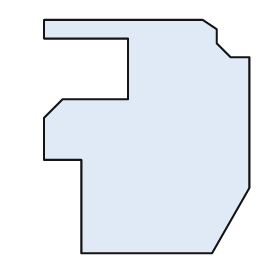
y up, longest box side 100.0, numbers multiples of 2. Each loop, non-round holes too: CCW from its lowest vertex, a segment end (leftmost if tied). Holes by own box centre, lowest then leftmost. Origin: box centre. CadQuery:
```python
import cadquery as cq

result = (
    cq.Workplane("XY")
    .moveTo(-28.0, -50.0)
    .lineTo(28.0, -50.0)
    .lineTo(44.0, -22.0)
    .lineTo(44.0, 34.0)
    .lineTo(36.0, 34.0)
    .lineTo(30.0, 40.0)
    .lineTo(30.0, 46.0)
    .lineTo(24.0, 50.0)
    .lineTo(-44.0, 50.0)
    .lineTo(-44.0, 42.0)
    .lineTo(-8.0, 42.0)
    .lineTo(-8.0, 16.0)
    .lineTo(-36.0, 16.0)
    .lineTo(-44.0, 8.0)
    .lineTo(-44.0, -10.0)
    .lineTo(-28.0, -10.0)
    .close()
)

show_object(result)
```